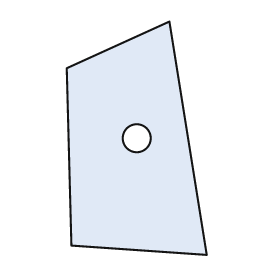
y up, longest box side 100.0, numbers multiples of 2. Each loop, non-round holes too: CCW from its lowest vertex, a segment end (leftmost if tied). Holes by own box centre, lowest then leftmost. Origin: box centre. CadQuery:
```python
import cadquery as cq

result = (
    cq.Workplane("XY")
    .moveTo(30.0, -50.0)
    .lineTo(14.0, 50.0)
    .lineTo(-30.0, 30.0)
    .lineTo(-28.0, -46.0)
    .close()
    .moveTo(0.0, 0.0)
    .circle(6.0)
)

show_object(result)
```